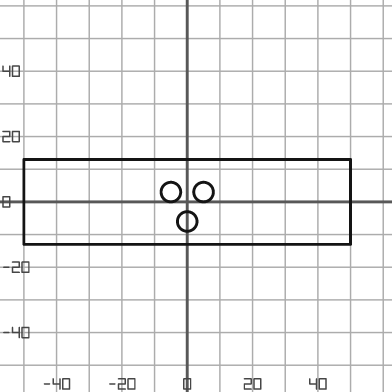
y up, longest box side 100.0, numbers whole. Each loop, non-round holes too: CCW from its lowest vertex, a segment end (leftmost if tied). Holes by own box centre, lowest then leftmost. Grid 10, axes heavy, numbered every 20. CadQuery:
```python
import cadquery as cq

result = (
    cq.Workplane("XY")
    .moveTo(-50.0, -13.0)
    .lineTo(50.0, -13.0)
    .lineTo(50.0, 13.0)
    .lineTo(-50.0, 13.0)
    .close()
    .moveTo(0.0, -6.0)
    .circle(3.0)
    .moveTo(-5.0, 3.0)
    .circle(3.0)
    .moveTo(5.0, 3.0)
    .circle(3.0)
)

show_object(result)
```